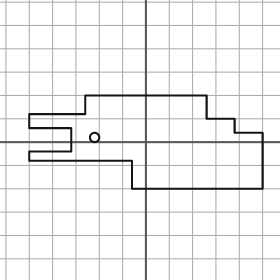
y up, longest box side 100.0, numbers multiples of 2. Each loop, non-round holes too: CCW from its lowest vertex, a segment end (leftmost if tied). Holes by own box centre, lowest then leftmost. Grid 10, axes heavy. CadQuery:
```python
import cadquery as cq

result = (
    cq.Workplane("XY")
    .moveTo(-6.0, -20.0)
    .lineTo(50.0, -20.0)
    .lineTo(50.0, 4.0)
    .lineTo(38.0, 4.0)
    .lineTo(38.0, 10.0)
    .lineTo(26.0, 10.0)
    .lineTo(26.0, 20.0)
    .lineTo(-26.0, 20.0)
    .lineTo(-26.0, 12.0)
    .lineTo(-50.0, 12.0)
    .lineTo(-50.0, 6.0)
    .lineTo(-32.0, 6.0)
    .lineTo(-32.0, -4.0)
    .lineTo(-50.0, -4.0)
    .lineTo(-50.0, -8.0)
    .lineTo(-6.0, -8.0)
    .close()
    .moveTo(-22.0, 2.0)
    .circle(2.0)
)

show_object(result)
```